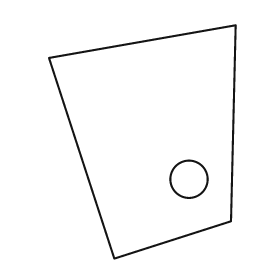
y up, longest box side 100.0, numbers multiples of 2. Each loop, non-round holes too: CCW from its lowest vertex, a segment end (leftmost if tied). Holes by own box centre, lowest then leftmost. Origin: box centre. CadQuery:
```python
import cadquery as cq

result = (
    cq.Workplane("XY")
    .moveTo(-12.0, -50.0)
    .lineTo(38.0, -34.0)
    .lineTo(40.0, 50.0)
    .lineTo(-40.0, 36.0)
    .close()
    .moveTo(20.0, -16.0)
    .circle(8.0)
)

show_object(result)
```